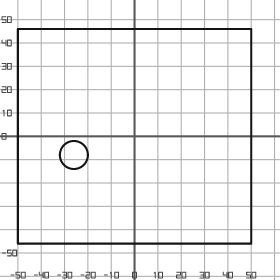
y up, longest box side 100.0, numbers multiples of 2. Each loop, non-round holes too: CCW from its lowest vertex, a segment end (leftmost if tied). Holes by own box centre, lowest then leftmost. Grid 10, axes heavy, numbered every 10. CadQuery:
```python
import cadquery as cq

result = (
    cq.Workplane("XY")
    .moveTo(-50.0, -46.0)
    .lineTo(50.0, -46.0)
    .lineTo(50.0, 46.0)
    .lineTo(-50.0, 46.0)
    .close()
    .moveTo(-26.0, -8.0)
    .circle(6.0)
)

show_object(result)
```